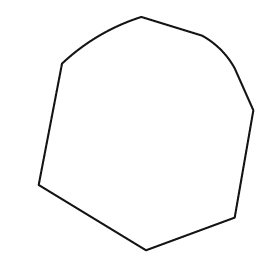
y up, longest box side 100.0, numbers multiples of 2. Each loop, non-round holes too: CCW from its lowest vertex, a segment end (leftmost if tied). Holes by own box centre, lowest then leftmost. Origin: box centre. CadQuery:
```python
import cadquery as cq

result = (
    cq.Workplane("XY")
    .moveTo(0.0, -50.0)
    .lineTo(38.0, -36.0)
    .lineTo(46.0, 10.0)
    .lineTo(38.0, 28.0)
    .threePointArc((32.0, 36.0), (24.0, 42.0))
    .lineTo(-2.0, 50.0)
    .threePointArc((-20.0, 42.0), (-36.0, 30.0))
    .lineTo(-46.0, -22.0)
    .close()
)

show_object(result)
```